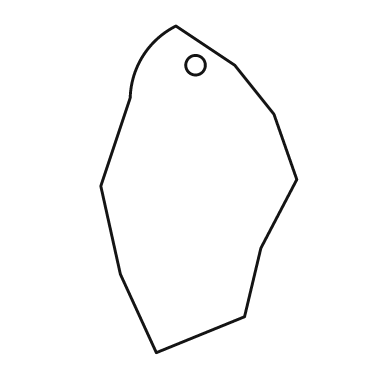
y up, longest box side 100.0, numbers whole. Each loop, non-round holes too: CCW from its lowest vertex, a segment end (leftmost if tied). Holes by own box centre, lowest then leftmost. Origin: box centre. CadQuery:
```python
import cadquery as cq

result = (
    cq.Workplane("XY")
    .moveTo(-13.0, -50.0)
    .lineTo(14.0, -39.0)
    .lineTo(19.0, -18.0)
    .lineTo(30.0, 3.0)
    .lineTo(23.0, 23.0)
    .lineTo(11.0, 38.0)
    .lineTo(-7.0, 50.0)
    .threePointArc((-17.0, 41.0), (-21.0, 28.0))
    .lineTo(-30.0, 1.0)
    .lineTo(-24.0, -26.0)
    .close()
    .moveTo(-1.0, 38.0)
    .circle(3.0)
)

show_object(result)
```